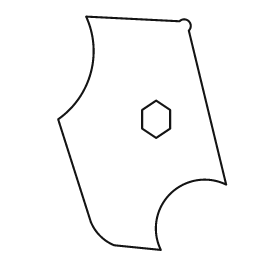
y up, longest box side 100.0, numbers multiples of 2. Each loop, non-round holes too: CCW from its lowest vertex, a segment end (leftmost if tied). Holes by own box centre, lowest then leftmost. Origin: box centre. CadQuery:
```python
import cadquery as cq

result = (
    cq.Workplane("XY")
    .moveTo(8.0, -50.0)
    .threePointArc((12.0, -26.0), (36.0, -22.0))
    .lineTo(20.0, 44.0)
    .threePointArc((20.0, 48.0), (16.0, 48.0))
    .lineTo(-24.0, 50.0)
    .threePointArc((-22.0, 26.0), (-36.0, 6.0))
    .lineTo(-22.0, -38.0)
    .threePointArc((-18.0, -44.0), (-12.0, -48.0))
    .close()
    .moveTo(6.0, -2.0)
    .lineTo(12.0, 2.0)
    .lineTo(12.0, 10.0)
    .lineTo(6.0, 14.0)
    .lineTo(0.0, 10.0)
    .lineTo(0.0, 2.0)
    .close()
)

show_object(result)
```